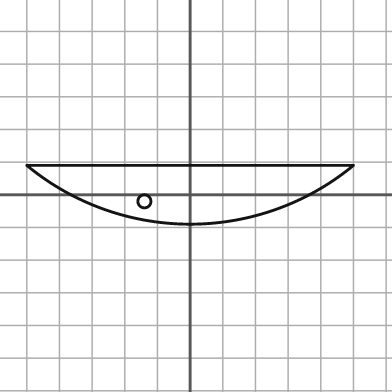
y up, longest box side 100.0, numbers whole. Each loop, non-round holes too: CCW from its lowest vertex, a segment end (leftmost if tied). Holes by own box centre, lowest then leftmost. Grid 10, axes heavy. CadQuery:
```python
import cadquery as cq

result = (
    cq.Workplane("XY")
    .moveTo(-50.0, 9.0)
    .threePointArc((0.0, -9.0), (50.0, 9.0))
    .close()
    .moveTo(-14.0, -2.0)
    .circle(2.0)
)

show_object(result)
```